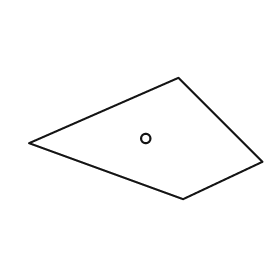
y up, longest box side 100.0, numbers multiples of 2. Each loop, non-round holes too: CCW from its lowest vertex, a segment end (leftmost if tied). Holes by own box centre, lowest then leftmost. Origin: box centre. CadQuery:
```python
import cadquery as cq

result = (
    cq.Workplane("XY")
    .moveTo(16.0, -26.0)
    .lineTo(50.0, -10.0)
    .lineTo(14.0, 26.0)
    .lineTo(-50.0, -2.0)
    .close()
    .moveTo(0.0, 0.0)
    .circle(2.0)
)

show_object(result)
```